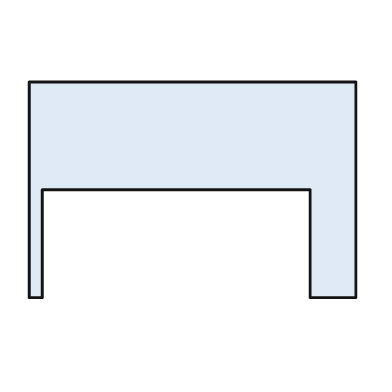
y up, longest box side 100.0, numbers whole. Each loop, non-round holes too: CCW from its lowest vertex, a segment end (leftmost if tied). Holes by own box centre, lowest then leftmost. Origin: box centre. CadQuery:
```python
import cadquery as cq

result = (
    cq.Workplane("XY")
    .moveTo(-50.0, -33.0)
    .lineTo(-46.0, -33.0)
    .lineTo(-46.0, 0.0)
    .lineTo(36.0, 0.0)
    .lineTo(36.0, -33.0)
    .lineTo(50.0, -33.0)
    .lineTo(50.0, 33.0)
    .lineTo(-50.0, 33.0)
    .close()
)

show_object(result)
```